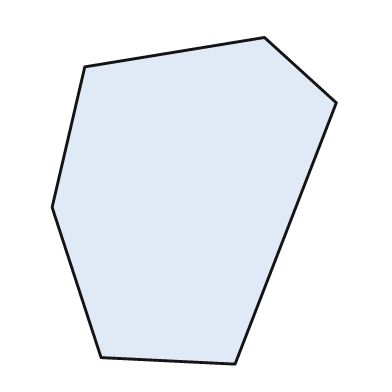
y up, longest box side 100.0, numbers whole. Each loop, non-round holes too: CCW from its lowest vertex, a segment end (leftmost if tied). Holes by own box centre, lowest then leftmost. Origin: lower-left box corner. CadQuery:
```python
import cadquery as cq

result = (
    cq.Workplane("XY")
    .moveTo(56.0, 0.0)
    .lineTo(87.0, 80.0)
    .lineTo(65.0, 100.0)
    .lineTo(10.0, 91.0)
    .lineTo(0.0, 48.0)
    .lineTo(15.0, 2.0)
    .close()
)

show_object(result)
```